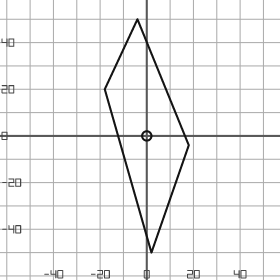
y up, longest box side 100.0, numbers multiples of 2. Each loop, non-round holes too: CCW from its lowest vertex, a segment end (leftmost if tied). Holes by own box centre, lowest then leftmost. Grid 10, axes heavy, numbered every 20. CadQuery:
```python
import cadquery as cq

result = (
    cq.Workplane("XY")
    .moveTo(2.0, -50.0)
    .lineTo(18.0, -4.0)
    .lineTo(-4.0, 50.0)
    .lineTo(-18.0, 20.0)
    .close()
    .moveTo(0.0, 0.0)
    .circle(2.0)
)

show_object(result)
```